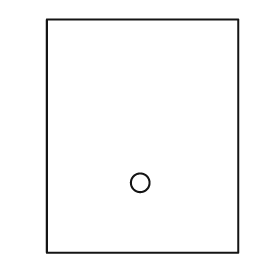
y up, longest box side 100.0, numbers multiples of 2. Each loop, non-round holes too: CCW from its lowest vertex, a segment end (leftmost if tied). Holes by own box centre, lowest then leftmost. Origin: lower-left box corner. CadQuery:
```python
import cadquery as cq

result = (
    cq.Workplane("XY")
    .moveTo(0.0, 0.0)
    .lineTo(82.0, 0.0)
    .lineTo(82.0, 100.0)
    .lineTo(0.0, 100.0)
    .close()
    .moveTo(40.0, 30.0)
    .circle(4.0)
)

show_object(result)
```